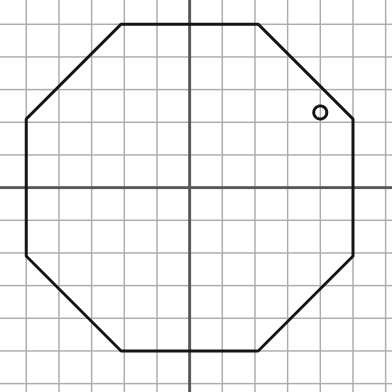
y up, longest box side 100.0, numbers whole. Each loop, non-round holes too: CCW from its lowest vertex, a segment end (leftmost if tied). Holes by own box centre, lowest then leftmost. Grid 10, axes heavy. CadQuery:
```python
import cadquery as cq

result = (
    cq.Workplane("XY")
    .moveTo(-21.0, -50.0)
    .lineTo(21.0, -50.0)
    .lineTo(50.0, -21.0)
    .lineTo(50.0, 21.0)
    .lineTo(21.0, 50.0)
    .lineTo(-21.0, 50.0)
    .lineTo(-50.0, 21.0)
    .lineTo(-50.0, -21.0)
    .close()
    .moveTo(40.0, 23.0)
    .circle(2.0)
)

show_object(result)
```